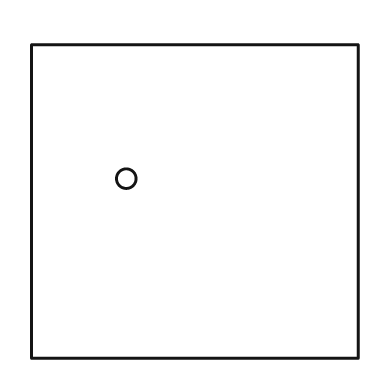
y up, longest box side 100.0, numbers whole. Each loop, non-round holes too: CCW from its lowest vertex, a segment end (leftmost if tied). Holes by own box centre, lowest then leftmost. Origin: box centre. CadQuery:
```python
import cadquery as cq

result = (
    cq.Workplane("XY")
    .moveTo(-50.0, -48.0)
    .lineTo(50.0, -48.0)
    .lineTo(50.0, 48.0)
    .lineTo(-50.0, 48.0)
    .close()
    .moveTo(-21.0, 7.0)
    .circle(3.0)
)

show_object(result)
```